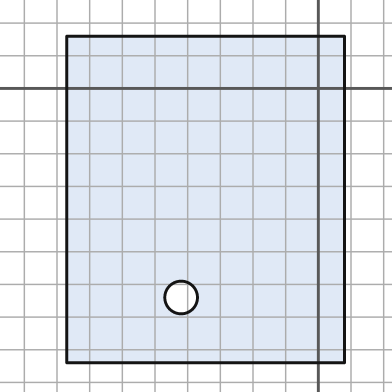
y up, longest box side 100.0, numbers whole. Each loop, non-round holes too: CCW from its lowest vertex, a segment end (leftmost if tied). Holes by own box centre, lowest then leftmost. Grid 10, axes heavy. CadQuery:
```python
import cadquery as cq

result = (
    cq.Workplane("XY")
    .moveTo(-77.0, -84.0)
    .lineTo(8.0, -84.0)
    .lineTo(8.0, 16.0)
    .lineTo(-77.0, 16.0)
    .close()
    .moveTo(-42.0, -64.0)
    .circle(5.0)
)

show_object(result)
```